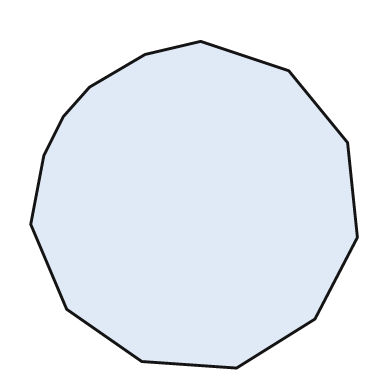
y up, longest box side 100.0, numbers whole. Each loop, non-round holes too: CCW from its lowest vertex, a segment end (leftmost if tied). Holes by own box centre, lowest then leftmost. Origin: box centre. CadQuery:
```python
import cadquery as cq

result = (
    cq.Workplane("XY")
    .moveTo(13.0, -50.0)
    .lineTo(37.0, -35.0)
    .lineTo(50.0, -10.0)
    .lineTo(47.0, 19.0)
    .lineTo(29.0, 41.0)
    .lineTo(2.0, 50.0)
    .lineTo(-15.0, 46.0)
    .lineTo(-32.0, 36.0)
    .lineTo(-40.0, 27.0)
    .lineTo(-46.0, 15.0)
    .lineTo(-50.0, -6.0)
    .lineTo(-39.0, -32.0)
    .lineTo(-16.0, -48.0)
    .close()
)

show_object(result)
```